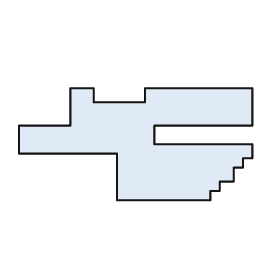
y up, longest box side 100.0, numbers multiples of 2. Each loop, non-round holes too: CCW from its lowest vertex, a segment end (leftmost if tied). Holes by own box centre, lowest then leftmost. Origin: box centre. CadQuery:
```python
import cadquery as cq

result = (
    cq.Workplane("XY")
    .moveTo(-8.0, -24.0)
    .lineTo(32.0, -24.0)
    .lineTo(32.0, -20.0)
    .lineTo(36.0, -20.0)
    .lineTo(36.0, -16.0)
    .lineTo(42.0, -16.0)
    .lineTo(42.0, -10.0)
    .lineTo(46.0, -10.0)
    .lineTo(46.0, -6.0)
    .lineTo(50.0, -6.0)
    .lineTo(50.0, 0.0)
    .lineTo(8.0, 0.0)
    .lineTo(8.0, 8.0)
    .lineTo(50.0, 8.0)
    .lineTo(50.0, 24.0)
    .lineTo(4.0, 24.0)
    .lineTo(4.0, 18.0)
    .lineTo(-18.0, 18.0)
    .lineTo(-18.0, 24.0)
    .lineTo(-28.0, 24.0)
    .lineTo(-28.0, 8.0)
    .lineTo(-50.0, 8.0)
    .lineTo(-50.0, -4.0)
    .lineTo(-8.0, -4.0)
    .close()
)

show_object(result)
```